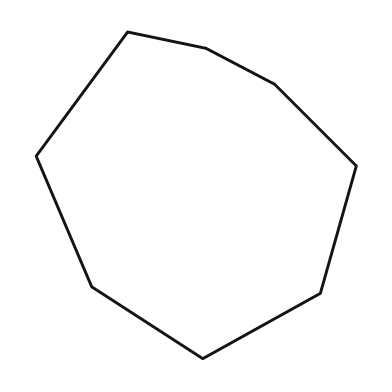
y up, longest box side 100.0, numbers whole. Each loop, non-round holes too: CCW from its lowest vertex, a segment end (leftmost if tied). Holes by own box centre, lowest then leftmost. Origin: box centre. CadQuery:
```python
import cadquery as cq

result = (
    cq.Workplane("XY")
    .moveTo(2.0, -50.0)
    .lineTo(38.0, -30.0)
    .lineTo(49.0, 9.0)
    .lineTo(24.0, 34.0)
    .lineTo(3.0, 45.0)
    .lineTo(-21.0, 50.0)
    .lineTo(-49.0, 12.0)
    .lineTo(-32.0, -28.0)
    .close()
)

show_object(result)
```